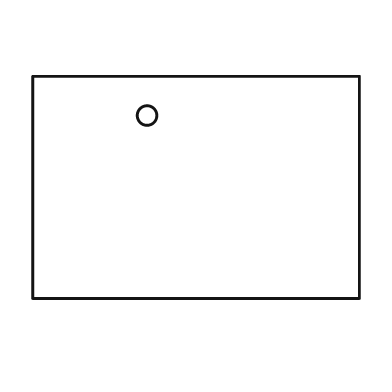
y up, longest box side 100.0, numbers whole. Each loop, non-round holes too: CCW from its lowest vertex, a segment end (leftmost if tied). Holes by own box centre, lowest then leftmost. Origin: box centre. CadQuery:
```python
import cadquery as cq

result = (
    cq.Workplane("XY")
    .moveTo(-50.0, -34.0)
    .lineTo(50.0, -34.0)
    .lineTo(50.0, 34.0)
    .lineTo(-50.0, 34.0)
    .close()
    .moveTo(-15.0, 22.0)
    .circle(3.0)
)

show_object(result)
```